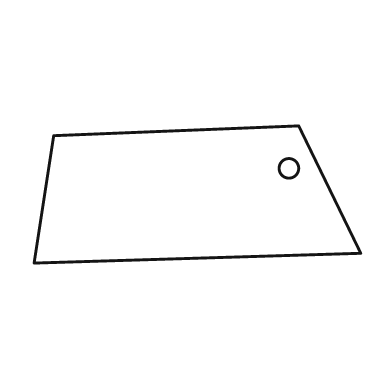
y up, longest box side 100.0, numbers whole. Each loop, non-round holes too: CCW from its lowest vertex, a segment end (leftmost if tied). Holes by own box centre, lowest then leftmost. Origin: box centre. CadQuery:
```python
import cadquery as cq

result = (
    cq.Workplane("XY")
    .moveTo(-50.0, -21.0)
    .lineTo(50.0, -18.0)
    .lineTo(31.0, 21.0)
    .lineTo(-44.0, 18.0)
    .close()
    .moveTo(28.0, 8.0)
    .circle(3.0)
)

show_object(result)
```